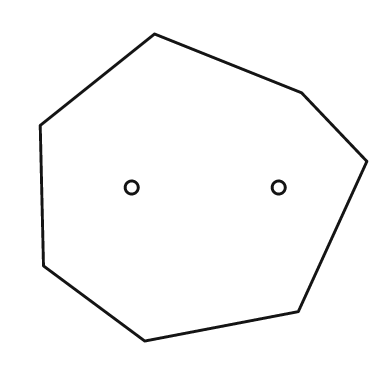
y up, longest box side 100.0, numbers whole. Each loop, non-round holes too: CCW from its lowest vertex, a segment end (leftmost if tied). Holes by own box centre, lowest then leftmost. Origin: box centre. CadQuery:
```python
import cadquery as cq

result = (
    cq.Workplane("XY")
    .moveTo(-18.0, -47.0)
    .lineTo(29.0, -38.0)
    .lineTo(50.0, 8.0)
    .lineTo(30.0, 29.0)
    .lineTo(-15.0, 47.0)
    .lineTo(-50.0, 19.0)
    .lineTo(-49.0, -24.0)
    .close()
    .moveTo(-22.0, 0.0)
    .circle(2.0)
    .moveTo(23.0, 0.0)
    .circle(2.0)
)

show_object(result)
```